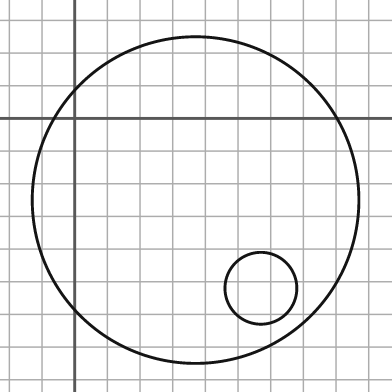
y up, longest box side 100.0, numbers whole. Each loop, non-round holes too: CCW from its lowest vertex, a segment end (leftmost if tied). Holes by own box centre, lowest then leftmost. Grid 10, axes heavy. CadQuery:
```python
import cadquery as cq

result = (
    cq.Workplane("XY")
    .moveTo(37.0, -25.0)
    .circle(50.0)
    .moveTo(57.0, -52.0)
    .circle(11.0)
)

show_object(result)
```